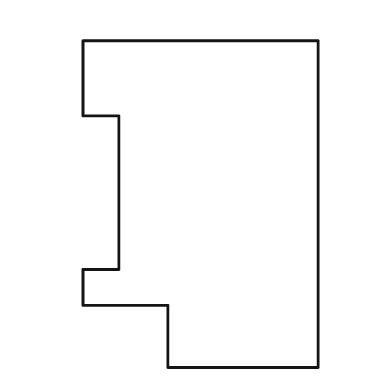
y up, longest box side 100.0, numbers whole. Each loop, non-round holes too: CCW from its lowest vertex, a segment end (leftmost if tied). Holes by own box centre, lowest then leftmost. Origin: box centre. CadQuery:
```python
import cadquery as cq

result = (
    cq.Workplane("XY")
    .moveTo(-10.0, -50.0)
    .lineTo(36.0, -50.0)
    .lineTo(36.0, 50.0)
    .lineTo(-36.0, 50.0)
    .lineTo(-36.0, 27.0)
    .lineTo(-25.0, 27.0)
    .lineTo(-25.0, -20.0)
    .lineTo(-36.0, -20.0)
    .lineTo(-36.0, -31.0)
    .lineTo(-10.0, -31.0)
    .close()
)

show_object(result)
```